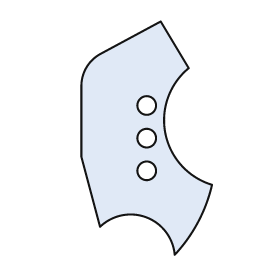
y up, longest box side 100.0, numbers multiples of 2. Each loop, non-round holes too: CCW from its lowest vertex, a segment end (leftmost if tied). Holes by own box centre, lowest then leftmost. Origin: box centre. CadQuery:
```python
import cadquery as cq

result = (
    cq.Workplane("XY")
    .moveTo(12.0, -50.0)
    .threePointArc((22.0, -36.0), (28.0, -20.0))
    .threePointArc((8.0, 2.0), (18.0, 30.0))
    .lineTo(6.0, 50.0)
    .lineTo(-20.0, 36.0)
    .threePointArc((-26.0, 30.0), (-28.0, 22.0))
    .lineTo(-28.0, -8.0)
    .lineTo(-20.0, -38.0)
    .threePointArc((0.0, -34.0), (12.0, -50.0))
    .close()
    .moveTo(0.0, -14.0)
    .circle(4.0)
    .moveTo(0.0, 0.0)
    .circle(4.0)
    .moveTo(0.0, 14.0)
    .circle(4.0)
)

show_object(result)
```